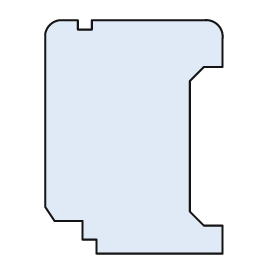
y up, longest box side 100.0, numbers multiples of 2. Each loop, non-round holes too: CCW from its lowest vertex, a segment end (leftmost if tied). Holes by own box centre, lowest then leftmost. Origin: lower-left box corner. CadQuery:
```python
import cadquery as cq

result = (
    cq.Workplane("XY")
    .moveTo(22.0, 0.0)
    .lineTo(76.0, 0.0)
    .lineTo(76.0, 12.0)
    .lineTo(68.0, 12.0)
    .lineTo(62.0, 18.0)
    .lineTo(62.0, 74.0)
    .lineTo(68.0, 80.0)
    .lineTo(76.0, 80.0)
    .lineTo(76.0, 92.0)
    .threePointArc((74.0, 98.0), (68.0, 100.0))
    .lineTo(20.0, 100.0)
    .lineTo(20.0, 96.0)
    .lineTo(14.0, 96.0)
    .lineTo(14.0, 100.0)
    .lineTo(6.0, 100.0)
    .threePointArc((2.0, 98.0), (0.0, 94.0))
    .lineTo(0.0, 20.0)
    .lineTo(4.0, 14.0)
    .lineTo(16.0, 14.0)
    .lineTo(16.0, 6.0)
    .lineTo(22.0, 6.0)
    .close()
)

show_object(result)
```